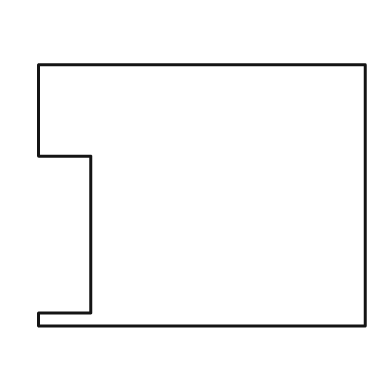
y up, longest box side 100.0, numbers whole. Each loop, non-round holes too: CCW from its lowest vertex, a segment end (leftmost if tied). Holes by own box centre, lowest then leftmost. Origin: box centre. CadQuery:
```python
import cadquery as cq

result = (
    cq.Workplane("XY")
    .moveTo(-50.0, -40.0)
    .lineTo(50.0, -40.0)
    .lineTo(50.0, 40.0)
    .lineTo(-50.0, 40.0)
    .lineTo(-50.0, 12.0)
    .lineTo(-34.0, 12.0)
    .lineTo(-34.0, -36.0)
    .lineTo(-50.0, -36.0)
    .close()
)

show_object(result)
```